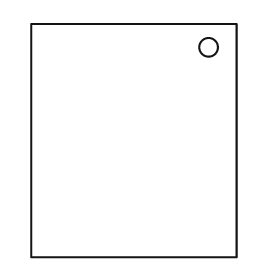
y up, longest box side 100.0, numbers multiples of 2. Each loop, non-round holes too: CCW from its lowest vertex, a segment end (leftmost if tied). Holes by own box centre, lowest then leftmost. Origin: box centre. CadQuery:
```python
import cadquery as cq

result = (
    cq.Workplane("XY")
    .moveTo(-44.0, -50.0)
    .lineTo(44.0, -50.0)
    .lineTo(44.0, 50.0)
    .lineTo(-44.0, 50.0)
    .close()
    .moveTo(32.0, 40.0)
    .circle(4.0)
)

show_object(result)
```